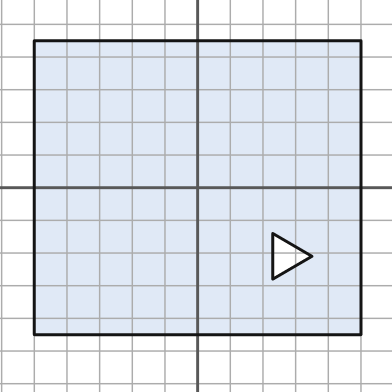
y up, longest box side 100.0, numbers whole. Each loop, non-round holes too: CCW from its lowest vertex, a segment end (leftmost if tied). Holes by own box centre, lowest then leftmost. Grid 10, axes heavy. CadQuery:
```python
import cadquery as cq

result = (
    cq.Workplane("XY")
    .moveTo(-50.0, -45.0)
    .lineTo(50.0, -45.0)
    .lineTo(50.0, 45.0)
    .lineTo(-50.0, 45.0)
    .close()
    .moveTo(23.0, -28.0)
    .lineTo(35.0, -21.0)
    .lineTo(23.0, -14.0)
    .close()
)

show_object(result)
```